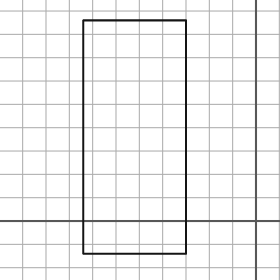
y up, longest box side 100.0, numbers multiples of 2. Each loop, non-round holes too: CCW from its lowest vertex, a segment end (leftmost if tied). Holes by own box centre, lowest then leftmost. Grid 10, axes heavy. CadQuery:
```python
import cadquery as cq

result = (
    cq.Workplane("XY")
    .moveTo(-74.0, -14.0)
    .lineTo(-30.0, -14.0)
    .lineTo(-30.0, 86.0)
    .lineTo(-74.0, 86.0)
    .close()
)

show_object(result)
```